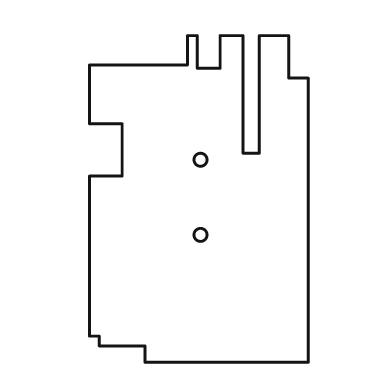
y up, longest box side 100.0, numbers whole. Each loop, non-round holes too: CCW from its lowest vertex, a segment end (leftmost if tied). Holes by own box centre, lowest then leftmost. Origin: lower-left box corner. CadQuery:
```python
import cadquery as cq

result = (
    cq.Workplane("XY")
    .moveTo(17.0, 0.0)
    .lineTo(67.0, 0.0)
    .lineTo(67.0, 87.0)
    .lineTo(61.0, 87.0)
    .lineTo(61.0, 100.0)
    .lineTo(52.0, 100.0)
    .lineTo(52.0, 64.0)
    .lineTo(47.0, 64.0)
    .lineTo(47.0, 100.0)
    .lineTo(40.0, 100.0)
    .lineTo(40.0, 90.0)
    .lineTo(33.0, 90.0)
    .lineTo(33.0, 100.0)
    .lineTo(30.0, 100.0)
    .lineTo(30.0, 91.0)
    .lineTo(0.0, 91.0)
    .lineTo(0.0, 73.0)
    .lineTo(10.0, 73.0)
    .lineTo(10.0, 57.0)
    .lineTo(0.0, 57.0)
    .lineTo(0.0, 8.0)
    .lineTo(3.0, 8.0)
    .lineTo(3.0, 5.0)
    .lineTo(17.0, 5.0)
    .close()
    .moveTo(34.0, 39.0)
    .circle(2.0)
    .moveTo(34.0, 62.0)
    .circle(2.0)
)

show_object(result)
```